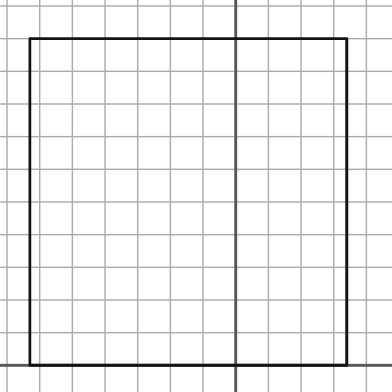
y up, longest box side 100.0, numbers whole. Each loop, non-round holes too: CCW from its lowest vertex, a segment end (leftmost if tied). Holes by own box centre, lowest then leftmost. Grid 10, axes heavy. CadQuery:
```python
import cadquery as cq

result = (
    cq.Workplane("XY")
    .moveTo(-63.0, 0.0)
    .lineTo(34.0, 0.0)
    .lineTo(34.0, 100.0)
    .lineTo(-63.0, 100.0)
    .close()
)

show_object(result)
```